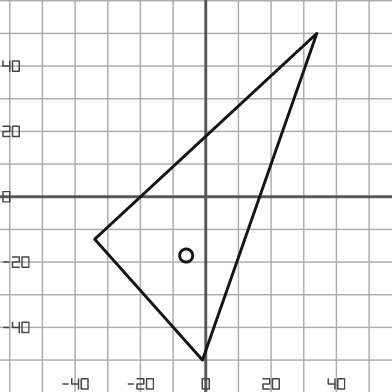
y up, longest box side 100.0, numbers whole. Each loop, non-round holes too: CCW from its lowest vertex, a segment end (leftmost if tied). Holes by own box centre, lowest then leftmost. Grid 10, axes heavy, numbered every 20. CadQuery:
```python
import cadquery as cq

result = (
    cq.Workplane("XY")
    .moveTo(-1.0, -50.0)
    .lineTo(34.0, 50.0)
    .lineTo(-34.0, -13.0)
    .close()
    .moveTo(-6.0, -18.0)
    .circle(2.0)
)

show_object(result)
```